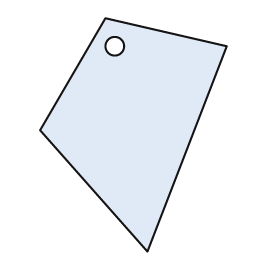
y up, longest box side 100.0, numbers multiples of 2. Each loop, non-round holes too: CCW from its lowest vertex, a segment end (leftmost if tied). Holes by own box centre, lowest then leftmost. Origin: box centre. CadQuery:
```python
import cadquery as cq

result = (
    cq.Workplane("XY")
    .moveTo(6.0, -50.0)
    .lineTo(40.0, 38.0)
    .lineTo(-12.0, 50.0)
    .lineTo(-40.0, 2.0)
    .close()
    .moveTo(-8.0, 38.0)
    .circle(4.0)
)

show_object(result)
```